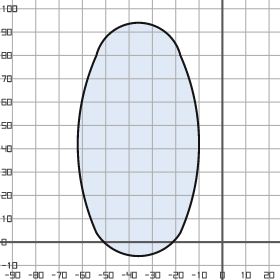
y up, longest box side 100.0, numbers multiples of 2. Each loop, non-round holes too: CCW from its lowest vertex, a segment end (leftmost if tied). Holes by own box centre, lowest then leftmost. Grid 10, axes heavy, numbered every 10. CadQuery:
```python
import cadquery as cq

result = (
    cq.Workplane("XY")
    .moveTo(-54.0, 4.0)
    .threePointArc((-36.0, -6.0), (-18.0, 4.0))
    .threePointArc((-10.0, 42.0), (-18.0, 80.0))
    .threePointArc((-36.0, 94.0), (-54.0, 80.0))
    .threePointArc((-62.0, 42.0), (-54.0, 4.0))
    .close()
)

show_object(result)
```